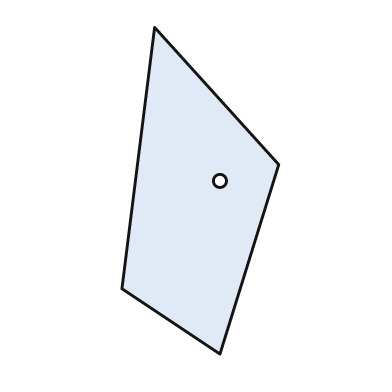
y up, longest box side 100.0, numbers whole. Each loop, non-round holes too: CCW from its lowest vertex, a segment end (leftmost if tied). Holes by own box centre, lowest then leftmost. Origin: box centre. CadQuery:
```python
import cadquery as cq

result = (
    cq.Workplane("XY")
    .moveTo(6.0, -50.0)
    .lineTo(24.0, 8.0)
    .lineTo(-14.0, 50.0)
    .lineTo(-24.0, -30.0)
    .close()
    .moveTo(6.0, 3.0)
    .circle(2.0)
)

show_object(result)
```